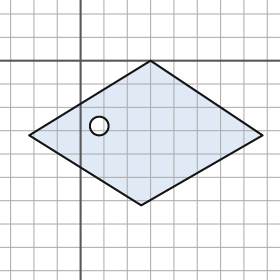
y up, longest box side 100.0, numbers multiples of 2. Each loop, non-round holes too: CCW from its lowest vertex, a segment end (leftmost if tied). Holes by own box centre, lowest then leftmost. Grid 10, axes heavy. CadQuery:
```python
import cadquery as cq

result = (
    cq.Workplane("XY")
    .moveTo(26.0, -62.0)
    .lineTo(78.0, -32.0)
    .lineTo(30.0, 0.0)
    .lineTo(-22.0, -32.0)
    .close()
    .moveTo(8.0, -28.0)
    .circle(4.0)
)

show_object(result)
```